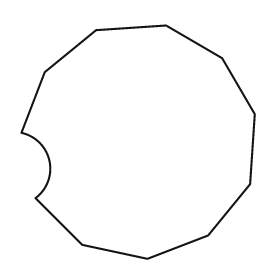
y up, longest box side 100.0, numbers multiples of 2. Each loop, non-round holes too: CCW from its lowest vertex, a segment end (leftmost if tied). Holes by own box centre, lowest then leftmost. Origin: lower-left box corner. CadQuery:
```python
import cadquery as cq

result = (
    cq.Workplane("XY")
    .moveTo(54.0, 0.0)
    .lineTo(80.0, 10.0)
    .lineTo(98.0, 32.0)
    .lineTo(100.0, 62.0)
    .lineTo(86.0, 86.0)
    .lineTo(62.0, 100.0)
    .lineTo(32.0, 98.0)
    .lineTo(10.0, 80.0)
    .lineTo(0.0, 54.0)
    .threePointArc((12.0, 42.0), (6.0, 26.0))
    .lineTo(26.0, 6.0)
    .close()
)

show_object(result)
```